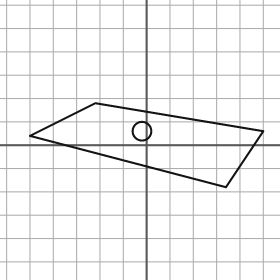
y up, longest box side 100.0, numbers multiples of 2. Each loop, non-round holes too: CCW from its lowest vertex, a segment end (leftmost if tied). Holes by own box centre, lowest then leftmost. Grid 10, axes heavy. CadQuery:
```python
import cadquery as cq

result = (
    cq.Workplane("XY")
    .moveTo(34.0, -18.0)
    .lineTo(50.0, 6.0)
    .lineTo(-22.0, 18.0)
    .lineTo(-50.0, 4.0)
    .close()
    .moveTo(-2.0, 6.0)
    .circle(4.0)
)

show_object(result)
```